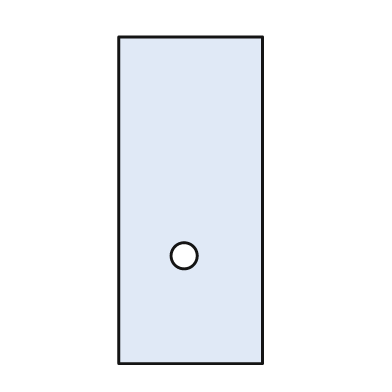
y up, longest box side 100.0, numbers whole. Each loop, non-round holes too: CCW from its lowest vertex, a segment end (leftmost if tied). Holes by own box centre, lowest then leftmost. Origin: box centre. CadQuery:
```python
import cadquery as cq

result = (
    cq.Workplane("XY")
    .moveTo(-22.0, -50.0)
    .lineTo(22.0, -50.0)
    .lineTo(22.0, 50.0)
    .lineTo(-22.0, 50.0)
    .close()
    .moveTo(-2.0, -17.0)
    .circle(4.0)
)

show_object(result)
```